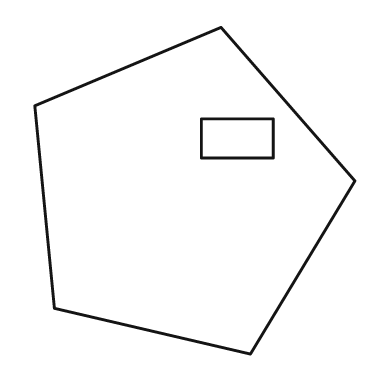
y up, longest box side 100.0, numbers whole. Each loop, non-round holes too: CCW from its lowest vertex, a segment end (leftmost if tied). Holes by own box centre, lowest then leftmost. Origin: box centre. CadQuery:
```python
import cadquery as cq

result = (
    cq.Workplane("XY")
    .moveTo(17.0, -50.0)
    .lineTo(49.0, 3.0)
    .lineTo(8.0, 50.0)
    .lineTo(-49.0, 26.0)
    .lineTo(-43.0, -36.0)
    .close()
    .moveTo(2.0, 10.0)
    .lineTo(24.0, 10.0)
    .lineTo(24.0, 22.0)
    .lineTo(2.0, 22.0)
    .close()
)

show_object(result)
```